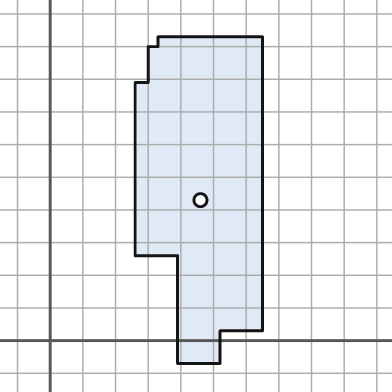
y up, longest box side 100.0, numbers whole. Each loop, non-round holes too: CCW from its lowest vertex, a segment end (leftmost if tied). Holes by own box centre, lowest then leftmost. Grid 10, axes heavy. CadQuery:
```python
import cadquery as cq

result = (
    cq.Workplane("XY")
    .moveTo(39.0, -7.0)
    .lineTo(52.0, -7.0)
    .lineTo(52.0, 3.0)
    .lineTo(65.0, 3.0)
    .lineTo(65.0, 93.0)
    .lineTo(33.0, 93.0)
    .lineTo(33.0, 90.0)
    .lineTo(30.0, 90.0)
    .lineTo(30.0, 79.0)
    .lineTo(26.0, 79.0)
    .lineTo(26.0, 26.0)
    .lineTo(39.0, 26.0)
    .close()
    .moveTo(46.0, 43.0)
    .circle(2.0)
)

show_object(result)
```